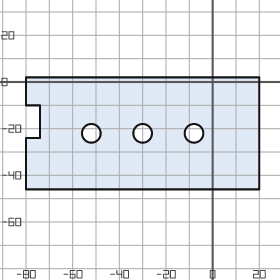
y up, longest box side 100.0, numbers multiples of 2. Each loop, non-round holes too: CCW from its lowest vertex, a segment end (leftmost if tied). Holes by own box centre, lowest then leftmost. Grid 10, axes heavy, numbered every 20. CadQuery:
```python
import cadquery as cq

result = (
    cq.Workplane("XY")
    .moveTo(-80.0, -46.0)
    .lineTo(20.0, -46.0)
    .lineTo(20.0, 2.0)
    .lineTo(-80.0, 2.0)
    .lineTo(-80.0, -10.0)
    .lineTo(-74.0, -10.0)
    .lineTo(-74.0, -24.0)
    .lineTo(-80.0, -24.0)
    .close()
    .moveTo(-52.0, -22.0)
    .circle(4.0)
    .moveTo(-30.0, -22.0)
    .circle(4.0)
    .moveTo(-8.0, -22.0)
    .circle(4.0)
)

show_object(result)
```